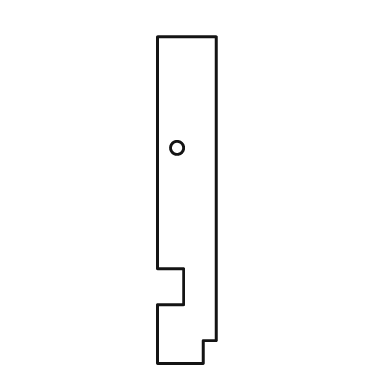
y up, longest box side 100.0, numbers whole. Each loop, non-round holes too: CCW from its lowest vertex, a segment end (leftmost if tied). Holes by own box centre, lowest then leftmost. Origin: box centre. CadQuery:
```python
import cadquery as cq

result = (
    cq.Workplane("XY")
    .moveTo(-9.0, -50.0)
    .lineTo(5.0, -50.0)
    .lineTo(5.0, -43.0)
    .lineTo(9.0, -43.0)
    .lineTo(9.0, 50.0)
    .lineTo(-9.0, 50.0)
    .lineTo(-9.0, -21.0)
    .lineTo(-1.0, -21.0)
    .lineTo(-1.0, -32.0)
    .lineTo(-9.0, -32.0)
    .close()
    .moveTo(-3.0, 16.0)
    .circle(2.0)
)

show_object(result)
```